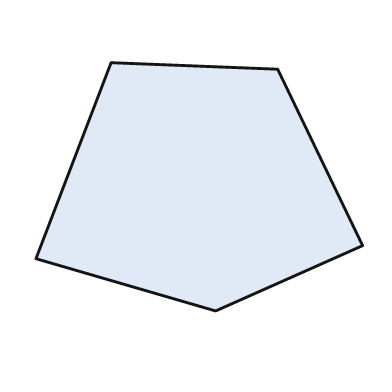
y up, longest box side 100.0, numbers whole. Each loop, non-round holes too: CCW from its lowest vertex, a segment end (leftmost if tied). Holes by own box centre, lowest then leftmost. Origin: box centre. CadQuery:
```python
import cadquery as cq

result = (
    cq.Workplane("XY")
    .moveTo(5.0, -38.0)
    .lineTo(50.0, -18.0)
    .lineTo(24.0, 36.0)
    .lineTo(-27.0, 38.0)
    .lineTo(-50.0, -22.0)
    .close()
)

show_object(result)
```